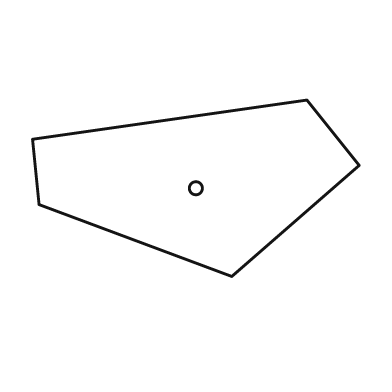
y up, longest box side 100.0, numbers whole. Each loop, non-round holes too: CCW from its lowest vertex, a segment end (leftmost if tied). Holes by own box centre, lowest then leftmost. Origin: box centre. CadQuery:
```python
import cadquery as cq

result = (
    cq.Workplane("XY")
    .moveTo(11.0, -27.0)
    .lineTo(50.0, 7.0)
    .lineTo(34.0, 27.0)
    .lineTo(-50.0, 15.0)
    .lineTo(-48.0, -5.0)
    .close()
    .moveTo(0.0, 0.0)
    .circle(2.0)
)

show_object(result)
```